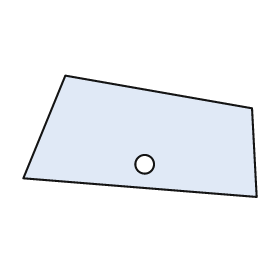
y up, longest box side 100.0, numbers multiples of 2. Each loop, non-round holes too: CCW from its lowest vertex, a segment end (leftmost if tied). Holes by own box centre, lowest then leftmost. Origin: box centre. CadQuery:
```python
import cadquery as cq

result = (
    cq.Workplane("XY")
    .moveTo(50.0, -26.0)
    .lineTo(48.0, 12.0)
    .lineTo(-32.0, 26.0)
    .lineTo(-50.0, -18.0)
    .close()
    .moveTo(2.0, -12.0)
    .circle(4.0)
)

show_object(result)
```